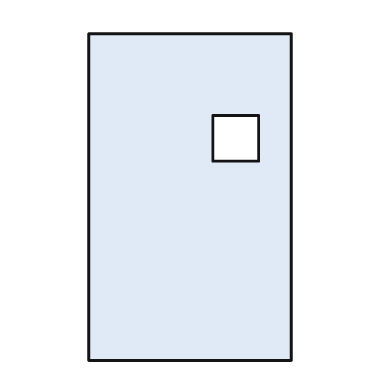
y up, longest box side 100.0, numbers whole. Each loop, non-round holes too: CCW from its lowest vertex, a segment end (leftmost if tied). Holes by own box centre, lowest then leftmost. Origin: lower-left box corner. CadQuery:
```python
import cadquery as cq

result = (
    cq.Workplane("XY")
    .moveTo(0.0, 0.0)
    .lineTo(62.0, 0.0)
    .lineTo(62.0, 100.0)
    .lineTo(0.0, 100.0)
    .close()
    .moveTo(38.0, 61.0)
    .lineTo(52.0, 61.0)
    .lineTo(52.0, 75.0)
    .lineTo(38.0, 75.0)
    .close()
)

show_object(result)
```